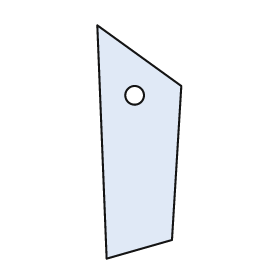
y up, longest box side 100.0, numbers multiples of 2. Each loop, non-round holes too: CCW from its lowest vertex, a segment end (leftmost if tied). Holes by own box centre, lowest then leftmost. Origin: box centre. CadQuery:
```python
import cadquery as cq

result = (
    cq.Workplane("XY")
    .moveTo(-14.0, -50.0)
    .lineTo(14.0, -42.0)
    .lineTo(18.0, 24.0)
    .lineTo(-18.0, 50.0)
    .close()
    .moveTo(-2.0, 20.0)
    .circle(4.0)
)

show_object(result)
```